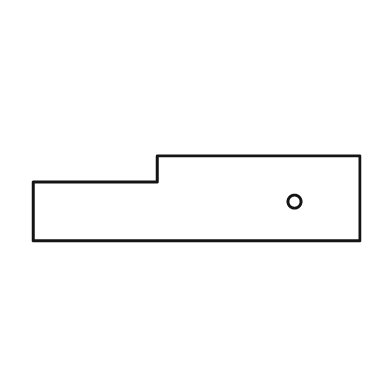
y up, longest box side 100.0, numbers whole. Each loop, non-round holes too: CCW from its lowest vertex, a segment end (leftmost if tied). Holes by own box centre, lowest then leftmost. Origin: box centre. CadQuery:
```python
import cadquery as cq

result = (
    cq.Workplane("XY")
    .moveTo(-50.0, -13.0)
    .lineTo(50.0, -13.0)
    .lineTo(50.0, 13.0)
    .lineTo(-12.0, 13.0)
    .lineTo(-12.0, 5.0)
    .lineTo(-50.0, 5.0)
    .close()
    .moveTo(30.0, -1.0)
    .circle(2.0)
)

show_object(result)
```